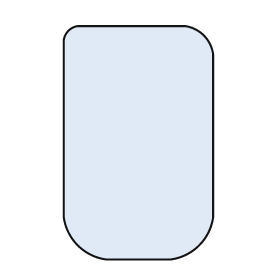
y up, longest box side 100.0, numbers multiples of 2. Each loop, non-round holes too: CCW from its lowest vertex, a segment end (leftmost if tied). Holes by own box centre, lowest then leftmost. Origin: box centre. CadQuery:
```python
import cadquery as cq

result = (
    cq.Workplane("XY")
    .moveTo(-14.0, -50.0)
    .lineTo(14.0, -50.0)
    .threePointArc((26.0, -44.0), (32.0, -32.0))
    .lineTo(32.0, 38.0)
    .threePointArc((28.0, 46.0), (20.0, 50.0))
    .lineTo(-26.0, 50.0)
    .threePointArc((-30.0, 48.0), (-32.0, 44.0))
    .lineTo(-32.0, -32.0)
    .threePointArc((-26.0, -44.0), (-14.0, -50.0))
    .close()
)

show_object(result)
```